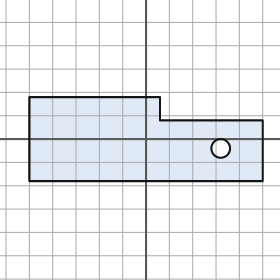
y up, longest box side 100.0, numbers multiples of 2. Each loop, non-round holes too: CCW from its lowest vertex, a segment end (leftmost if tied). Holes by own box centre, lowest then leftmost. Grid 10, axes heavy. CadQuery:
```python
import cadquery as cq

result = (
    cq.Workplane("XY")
    .moveTo(-50.0, -18.0)
    .lineTo(50.0, -18.0)
    .lineTo(50.0, 8.0)
    .lineTo(6.0, 8.0)
    .lineTo(6.0, 18.0)
    .lineTo(-50.0, 18.0)
    .close()
    .moveTo(32.0, -4.0)
    .circle(4.0)
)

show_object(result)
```